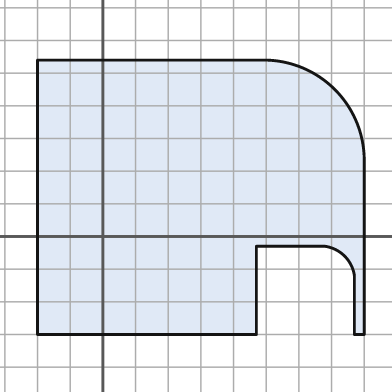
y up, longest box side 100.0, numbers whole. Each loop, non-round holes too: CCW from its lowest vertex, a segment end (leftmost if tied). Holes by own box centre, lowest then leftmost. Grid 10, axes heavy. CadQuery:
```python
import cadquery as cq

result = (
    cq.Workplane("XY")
    .moveTo(-20.0, -30.0)
    .lineTo(47.0, -30.0)
    .lineTo(47.0, -3.0)
    .lineTo(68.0, -3.0)
    .threePointArc((74.0, -6.0), (77.0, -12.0))
    .lineTo(77.0, -30.0)
    .lineTo(80.0, -30.0)
    .lineTo(80.0, 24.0)
    .threePointArc((71.0, 45.0), (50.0, 54.0))
    .lineTo(-20.0, 54.0)
    .close()
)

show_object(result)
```